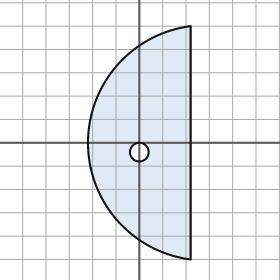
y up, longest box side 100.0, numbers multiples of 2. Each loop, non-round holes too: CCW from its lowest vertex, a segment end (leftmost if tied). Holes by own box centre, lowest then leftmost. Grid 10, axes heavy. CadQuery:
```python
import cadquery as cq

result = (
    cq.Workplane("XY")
    .moveTo(22.0, -50.0)
    .lineTo(22.0, 50.0)
    .threePointArc((-22.0, 0.0), (22.0, -50.0))
    .close()
    .moveTo(0.0, -4.0)
    .circle(4.0)
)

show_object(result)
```